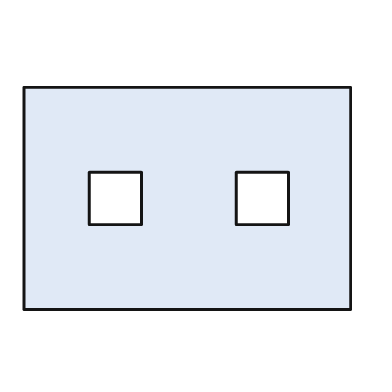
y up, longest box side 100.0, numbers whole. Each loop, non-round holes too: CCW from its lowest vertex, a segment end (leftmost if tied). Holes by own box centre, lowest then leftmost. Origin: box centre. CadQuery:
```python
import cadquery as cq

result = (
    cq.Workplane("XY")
    .moveTo(-50.0, -34.0)
    .lineTo(50.0, -34.0)
    .lineTo(50.0, 34.0)
    .lineTo(-50.0, 34.0)
    .close()
    .moveTo(-30.0, -8.0)
    .lineTo(-14.0, -8.0)
    .lineTo(-14.0, 8.0)
    .lineTo(-30.0, 8.0)
    .close()
    .moveTo(15.0, -8.0)
    .lineTo(31.0, -8.0)
    .lineTo(31.0, 8.0)
    .lineTo(15.0, 8.0)
    .close()
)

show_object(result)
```